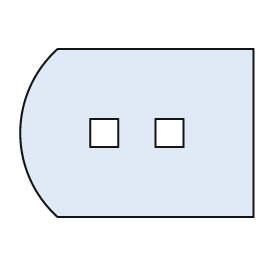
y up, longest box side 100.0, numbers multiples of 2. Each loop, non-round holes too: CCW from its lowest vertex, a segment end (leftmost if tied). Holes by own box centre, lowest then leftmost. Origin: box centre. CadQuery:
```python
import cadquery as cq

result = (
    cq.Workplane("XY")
    .moveTo(-34.0, -36.0)
    .lineTo(50.0, -36.0)
    .lineTo(50.0, 36.0)
    .lineTo(-34.0, 36.0)
    .threePointArc((-50.0, 0.0), (-34.0, -36.0))
    .close()
    .moveTo(-20.0, -6.0)
    .lineTo(-8.0, -6.0)
    .lineTo(-8.0, 6.0)
    .lineTo(-20.0, 6.0)
    .close()
    .moveTo(8.0, -6.0)
    .lineTo(20.0, -6.0)
    .lineTo(20.0, 6.0)
    .lineTo(8.0, 6.0)
    .close()
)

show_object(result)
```